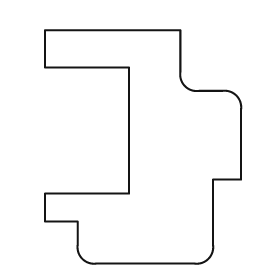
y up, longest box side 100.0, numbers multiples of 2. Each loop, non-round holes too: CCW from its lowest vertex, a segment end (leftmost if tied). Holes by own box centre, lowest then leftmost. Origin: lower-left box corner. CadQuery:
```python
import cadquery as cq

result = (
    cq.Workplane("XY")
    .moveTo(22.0, 0.0)
    .lineTo(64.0, 0.0)
    .threePointArc((70.0, 2.0), (72.0, 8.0))
    .lineTo(72.0, 36.0)
    .lineTo(84.0, 36.0)
    .lineTo(84.0, 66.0)
    .threePointArc((82.0, 72.0), (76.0, 74.0))
    .lineTo(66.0, 74.0)
    .threePointArc((60.0, 76.0), (58.0, 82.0))
    .lineTo(58.0, 100.0)
    .lineTo(0.0, 100.0)
    .lineTo(0.0, 84.0)
    .lineTo(36.0, 84.0)
    .lineTo(36.0, 30.0)
    .lineTo(0.0, 30.0)
    .lineTo(0.0, 18.0)
    .lineTo(14.0, 18.0)
    .lineTo(14.0, 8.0)
    .threePointArc((16.0, 2.0), (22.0, 0.0))
    .close()
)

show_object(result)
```